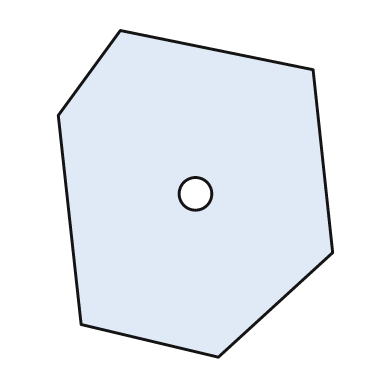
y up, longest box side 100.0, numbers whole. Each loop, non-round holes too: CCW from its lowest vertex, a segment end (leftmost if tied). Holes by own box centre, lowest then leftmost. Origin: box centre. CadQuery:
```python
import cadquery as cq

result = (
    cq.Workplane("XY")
    .moveTo(7.0, -50.0)
    .lineTo(42.0, -18.0)
    .lineTo(36.0, 38.0)
    .lineTo(-23.0, 50.0)
    .lineTo(-42.0, 24.0)
    .lineTo(-35.0, -40.0)
    .close()
    .moveTo(0.0, 0.0)
    .circle(5.0)
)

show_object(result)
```